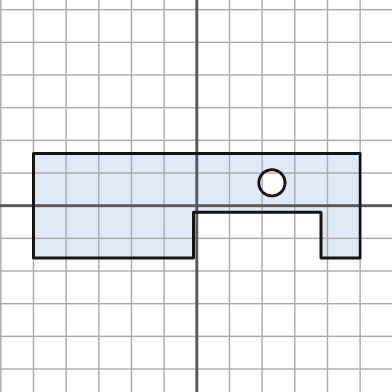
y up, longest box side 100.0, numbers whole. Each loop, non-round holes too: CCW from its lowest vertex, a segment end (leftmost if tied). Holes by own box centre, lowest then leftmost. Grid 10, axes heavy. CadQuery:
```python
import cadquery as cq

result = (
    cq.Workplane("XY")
    .moveTo(-50.0, -16.0)
    .lineTo(-1.0, -16.0)
    .lineTo(-1.0, -2.0)
    .lineTo(38.0, -2.0)
    .lineTo(38.0, -16.0)
    .lineTo(50.0, -16.0)
    .lineTo(50.0, 16.0)
    .lineTo(-50.0, 16.0)
    .close()
    .moveTo(23.0, 7.0)
    .circle(4.0)
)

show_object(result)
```